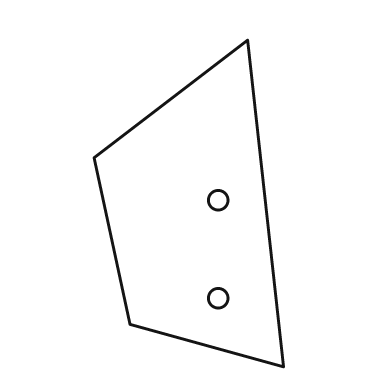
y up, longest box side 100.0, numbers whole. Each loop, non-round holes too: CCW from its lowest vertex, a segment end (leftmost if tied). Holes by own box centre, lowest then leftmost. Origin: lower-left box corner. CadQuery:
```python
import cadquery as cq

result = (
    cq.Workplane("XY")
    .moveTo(58.0, 0.0)
    .lineTo(47.0, 100.0)
    .lineTo(0.0, 64.0)
    .lineTo(11.0, 13.0)
    .close()
    .moveTo(38.0, 21.0)
    .circle(3.0)
    .moveTo(38.0, 51.0)
    .circle(3.0)
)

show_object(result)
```